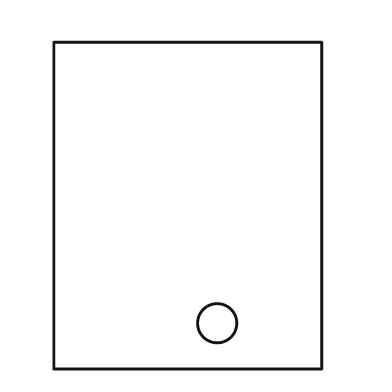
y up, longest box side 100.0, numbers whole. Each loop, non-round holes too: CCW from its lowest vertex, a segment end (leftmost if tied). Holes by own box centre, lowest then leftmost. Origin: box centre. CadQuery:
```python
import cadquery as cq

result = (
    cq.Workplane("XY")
    .moveTo(-41.0, -50.0)
    .lineTo(41.0, -50.0)
    .lineTo(41.0, 50.0)
    .lineTo(-41.0, 50.0)
    .close()
    .moveTo(9.0, -36.0)
    .circle(6.0)
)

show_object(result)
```